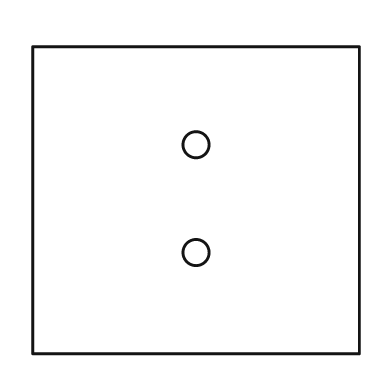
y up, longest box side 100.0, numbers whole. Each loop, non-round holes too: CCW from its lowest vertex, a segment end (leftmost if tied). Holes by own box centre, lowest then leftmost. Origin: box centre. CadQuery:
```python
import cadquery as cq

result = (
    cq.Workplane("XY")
    .moveTo(-50.0, -47.0)
    .lineTo(50.0, -47.0)
    .lineTo(50.0, 47.0)
    .lineTo(-50.0, 47.0)
    .close()
    .moveTo(0.0, -16.0)
    .circle(4.0)
    .moveTo(0.0, 17.0)
    .circle(4.0)
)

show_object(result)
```